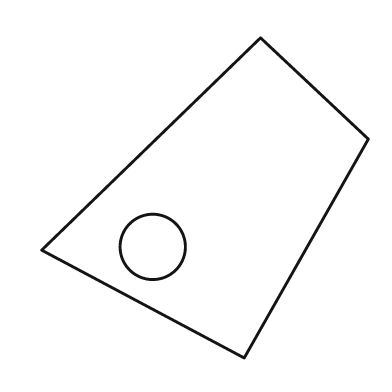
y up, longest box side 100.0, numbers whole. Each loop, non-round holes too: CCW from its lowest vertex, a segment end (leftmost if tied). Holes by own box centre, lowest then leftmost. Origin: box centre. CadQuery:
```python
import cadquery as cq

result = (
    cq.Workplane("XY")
    .moveTo(12.0, -49.0)
    .lineTo(50.0, 18.0)
    .lineTo(17.0, 49.0)
    .lineTo(-50.0, -16.0)
    .close()
    .moveTo(-16.0, -15.0)
    .circle(10.0)
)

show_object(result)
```